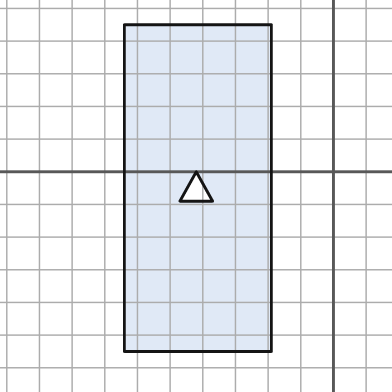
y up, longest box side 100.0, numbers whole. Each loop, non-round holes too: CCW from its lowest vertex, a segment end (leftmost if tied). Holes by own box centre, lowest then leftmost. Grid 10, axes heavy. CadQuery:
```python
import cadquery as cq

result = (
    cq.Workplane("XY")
    .moveTo(-64.0, -55.0)
    .lineTo(-19.0, -55.0)
    .lineTo(-19.0, 45.0)
    .lineTo(-64.0, 45.0)
    .close()
    .moveTo(-47.0, -9.0)
    .lineTo(-37.0, -9.0)
    .lineTo(-42.0, 0.0)
    .close()
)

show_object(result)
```